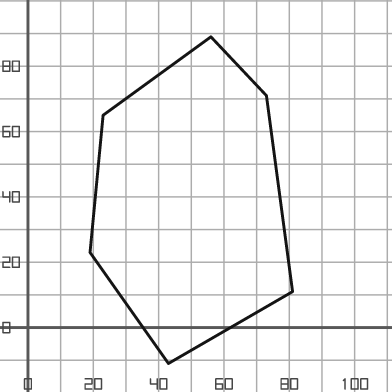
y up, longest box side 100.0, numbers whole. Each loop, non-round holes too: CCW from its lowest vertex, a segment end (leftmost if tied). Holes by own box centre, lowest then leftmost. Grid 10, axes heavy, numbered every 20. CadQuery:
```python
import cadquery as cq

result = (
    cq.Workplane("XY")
    .moveTo(43.0, -11.0)
    .lineTo(81.0, 11.0)
    .lineTo(73.0, 71.0)
    .lineTo(56.0, 89.0)
    .lineTo(23.0, 65.0)
    .lineTo(19.0, 23.0)
    .close()
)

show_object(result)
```